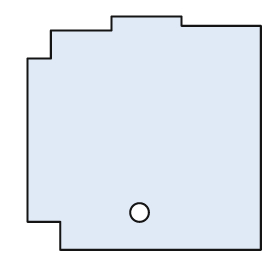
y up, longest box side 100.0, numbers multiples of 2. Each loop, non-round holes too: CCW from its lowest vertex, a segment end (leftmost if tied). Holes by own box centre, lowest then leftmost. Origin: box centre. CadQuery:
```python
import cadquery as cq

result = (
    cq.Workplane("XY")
    .moveTo(-36.0, -50.0)
    .lineTo(50.0, -50.0)
    .lineTo(50.0, 46.0)
    .lineTo(16.0, 46.0)
    .lineTo(16.0, 50.0)
    .lineTo(-14.0, 50.0)
    .lineTo(-14.0, 44.0)
    .lineTo(-40.0, 44.0)
    .lineTo(-40.0, 32.0)
    .lineTo(-50.0, 32.0)
    .lineTo(-50.0, -38.0)
    .lineTo(-36.0, -38.0)
    .close()
    .moveTo(-2.0, -34.0)
    .circle(4.0)
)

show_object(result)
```